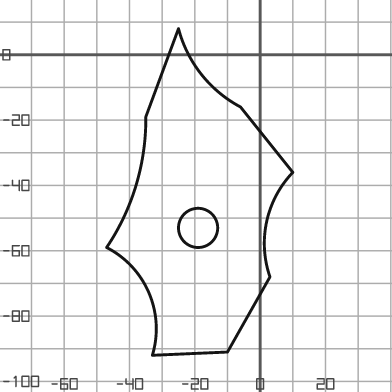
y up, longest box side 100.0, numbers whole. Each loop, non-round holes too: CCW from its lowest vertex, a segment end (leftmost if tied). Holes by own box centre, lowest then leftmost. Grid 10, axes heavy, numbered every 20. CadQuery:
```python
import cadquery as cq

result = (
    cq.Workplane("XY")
    .moveTo(-33.0, -92.0)
    .lineTo(-10.0, -91.0)
    .lineTo(3.0, -68.0)
    .threePointArc((2.0, -51.0), (10.0, -36.0))
    .lineTo(-6.0, -16.0)
    .threePointArc((-18.0, -6.0), (-25.0, 8.0))
    .lineTo(-35.0, -19.0)
    .threePointArc((-38.0, -40.0), (-47.0, -59.0))
    .threePointArc((-34.0, -73.0), (-33.0, -92.0))
    .close()
    .moveTo(-19.0, -53.0)
    .circle(6.0)
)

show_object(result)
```